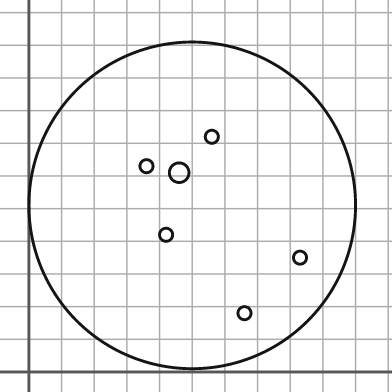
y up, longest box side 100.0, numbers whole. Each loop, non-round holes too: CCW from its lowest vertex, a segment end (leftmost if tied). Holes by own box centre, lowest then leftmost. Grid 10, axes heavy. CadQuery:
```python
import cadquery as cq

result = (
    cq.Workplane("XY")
    .moveTo(50.0, 51.0)
    .circle(50.0)
    .moveTo(66.0, 18.0)
    .circle(2.0)
    .moveTo(83.0, 35.0)
    .circle(2.0)
    .moveTo(42.0, 42.0)
    .circle(2.0)
    .moveTo(46.0, 61.0)
    .circle(3.0)
    .moveTo(36.0, 63.0)
    .circle(2.0)
    .moveTo(56.0, 72.0)
    .circle(2.0)
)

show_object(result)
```